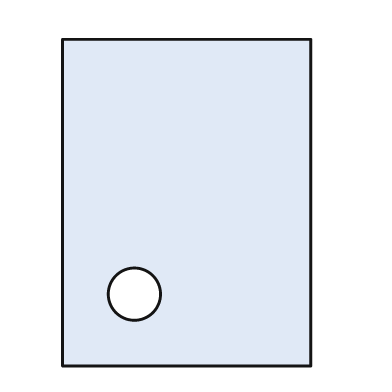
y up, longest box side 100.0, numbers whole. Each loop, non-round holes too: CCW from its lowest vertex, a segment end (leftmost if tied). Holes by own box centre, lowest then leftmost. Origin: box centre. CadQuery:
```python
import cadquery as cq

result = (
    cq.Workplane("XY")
    .moveTo(-38.0, -50.0)
    .lineTo(38.0, -50.0)
    .lineTo(38.0, 50.0)
    .lineTo(-38.0, 50.0)
    .close()
    .moveTo(-16.0, -28.0)
    .circle(8.0)
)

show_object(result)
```